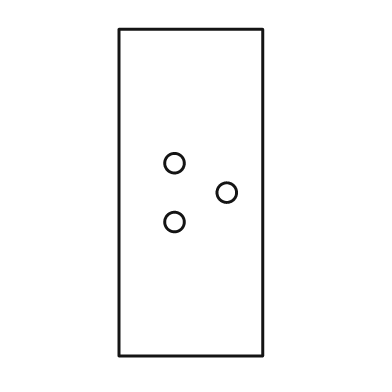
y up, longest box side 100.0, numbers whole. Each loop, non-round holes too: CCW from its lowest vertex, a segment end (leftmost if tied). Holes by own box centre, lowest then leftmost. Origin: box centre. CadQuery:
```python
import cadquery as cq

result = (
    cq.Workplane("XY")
    .moveTo(-22.0, -50.0)
    .lineTo(22.0, -50.0)
    .lineTo(22.0, 50.0)
    .lineTo(-22.0, 50.0)
    .close()
    .moveTo(-5.0, -9.0)
    .circle(3.0)
    .moveTo(11.0, 0.0)
    .circle(3.0)
    .moveTo(-5.0, 9.0)
    .circle(3.0)
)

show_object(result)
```